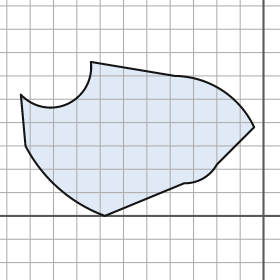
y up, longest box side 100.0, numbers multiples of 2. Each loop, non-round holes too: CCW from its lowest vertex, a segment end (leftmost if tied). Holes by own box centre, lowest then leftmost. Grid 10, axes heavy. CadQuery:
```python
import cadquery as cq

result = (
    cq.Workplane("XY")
    .moveTo(-68.0, 0.0)
    .lineTo(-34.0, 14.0)
    .threePointArc((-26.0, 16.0), (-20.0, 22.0))
    .lineTo(-4.0, 38.0)
    .threePointArc((-18.0, 54.0), (-38.0, 60.0))
    .lineTo(-74.0, 66.0)
    .threePointArc((-84.0, 48.0), (-104.0, 52.0))
    .lineTo(-102.0, 30.0)
    .threePointArc((-88.0, 12.0), (-68.0, 0.0))
    .close()
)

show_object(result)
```